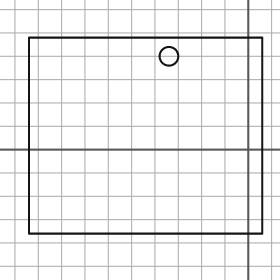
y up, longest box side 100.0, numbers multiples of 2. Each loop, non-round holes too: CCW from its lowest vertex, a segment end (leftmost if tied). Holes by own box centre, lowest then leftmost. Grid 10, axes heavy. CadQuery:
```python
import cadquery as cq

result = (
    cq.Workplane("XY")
    .moveTo(-94.0, -36.0)
    .lineTo(6.0, -36.0)
    .lineTo(6.0, 48.0)
    .lineTo(-94.0, 48.0)
    .close()
    .moveTo(-34.0, 40.0)
    .circle(4.0)
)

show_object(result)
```